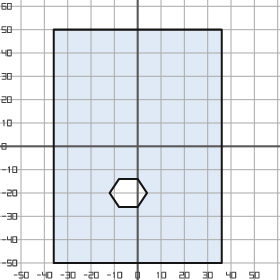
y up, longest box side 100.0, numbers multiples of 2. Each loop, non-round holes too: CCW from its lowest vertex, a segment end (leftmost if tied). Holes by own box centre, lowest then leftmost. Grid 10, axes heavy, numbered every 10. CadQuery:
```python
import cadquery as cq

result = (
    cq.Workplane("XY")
    .moveTo(-36.0, -50.0)
    .lineTo(36.0, -50.0)
    .lineTo(36.0, 50.0)
    .lineTo(-36.0, 50.0)
    .close()
    .moveTo(-8.0, -26.0)
    .lineTo(0.0, -26.0)
    .lineTo(4.0, -20.0)
    .lineTo(0.0, -14.0)
    .lineTo(-8.0, -14.0)
    .lineTo(-12.0, -20.0)
    .close()
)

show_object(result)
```